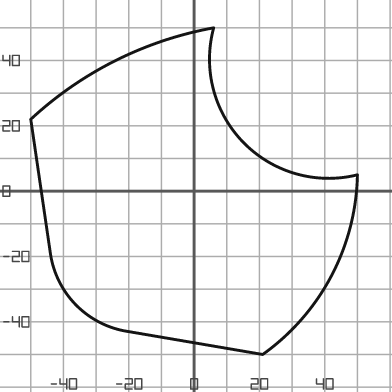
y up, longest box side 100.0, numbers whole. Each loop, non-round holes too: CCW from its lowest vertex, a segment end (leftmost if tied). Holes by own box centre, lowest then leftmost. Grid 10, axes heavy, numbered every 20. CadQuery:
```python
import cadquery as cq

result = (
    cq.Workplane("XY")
    .moveTo(21.0, -50.0)
    .threePointArc((42.0, -26.0), (50.0, 5.0))
    .threePointArc((15.0, 15.0), (6.0, 50.0))
    .threePointArc((-24.0, 40.0), (-50.0, 22.0))
    .lineTo(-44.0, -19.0)
    .threePointArc((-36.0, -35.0), (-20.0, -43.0))
    .close()
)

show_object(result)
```